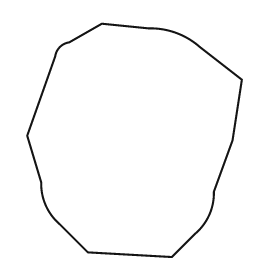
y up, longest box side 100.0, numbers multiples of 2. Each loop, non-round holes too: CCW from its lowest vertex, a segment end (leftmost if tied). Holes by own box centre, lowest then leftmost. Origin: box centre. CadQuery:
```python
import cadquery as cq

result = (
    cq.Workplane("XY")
    .moveTo(16.0, -50.0)
    .lineTo(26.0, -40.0)
    .threePointArc((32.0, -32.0), (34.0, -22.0))
    .lineTo(42.0, 0.0)
    .lineTo(46.0, 26.0)
    .lineTo(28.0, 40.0)
    .threePointArc((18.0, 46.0), (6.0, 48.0))
    .lineTo(-14.0, 50.0)
    .lineTo(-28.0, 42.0)
    .threePointArc((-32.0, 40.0), (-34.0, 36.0))
    .lineTo(-46.0, 2.0)
    .lineTo(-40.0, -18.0)
    .threePointArc((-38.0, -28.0), (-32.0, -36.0))
    .lineTo(-20.0, -48.0)
    .close()
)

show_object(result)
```